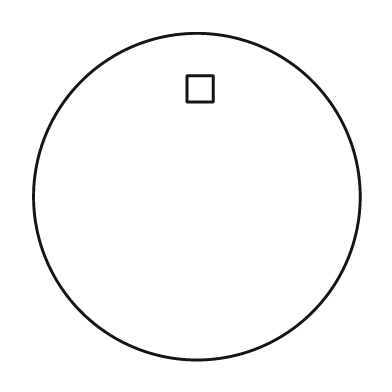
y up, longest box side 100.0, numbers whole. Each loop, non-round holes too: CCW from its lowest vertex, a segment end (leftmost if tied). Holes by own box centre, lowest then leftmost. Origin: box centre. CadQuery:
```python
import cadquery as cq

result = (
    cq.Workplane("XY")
    .moveTo(0.0, 0.0)
    .circle(50.0)
    .moveTo(-3.0, 29.0)
    .lineTo(5.0, 29.0)
    .lineTo(5.0, 37.0)
    .lineTo(-3.0, 37.0)
    .close()
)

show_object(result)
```